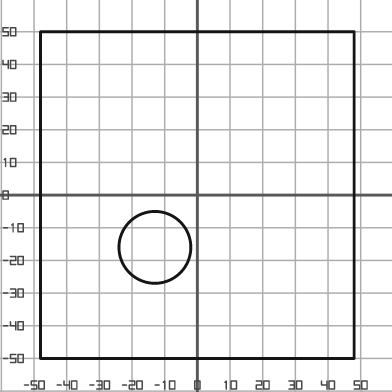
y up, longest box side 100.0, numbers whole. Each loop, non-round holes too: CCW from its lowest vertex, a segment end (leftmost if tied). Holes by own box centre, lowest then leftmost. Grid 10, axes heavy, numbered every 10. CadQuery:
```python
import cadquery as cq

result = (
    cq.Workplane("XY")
    .moveTo(-48.0, -50.0)
    .lineTo(48.0, -50.0)
    .lineTo(48.0, 50.0)
    .lineTo(-48.0, 50.0)
    .close()
    .moveTo(-13.0, -16.0)
    .circle(11.0)
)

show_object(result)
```